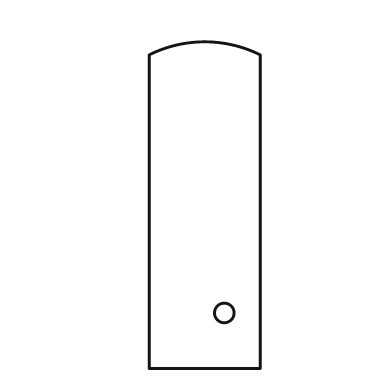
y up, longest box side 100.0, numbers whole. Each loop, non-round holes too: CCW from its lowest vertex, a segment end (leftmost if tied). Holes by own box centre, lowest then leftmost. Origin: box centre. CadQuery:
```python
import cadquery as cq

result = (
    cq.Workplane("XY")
    .moveTo(-17.0, -50.0)
    .lineTo(17.0, -50.0)
    .lineTo(17.0, 46.0)
    .threePointArc((0.0, 50.0), (-17.0, 46.0))
    .close()
    .moveTo(6.0, -33.0)
    .circle(3.0)
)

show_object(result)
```